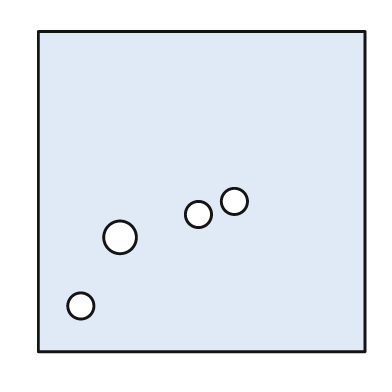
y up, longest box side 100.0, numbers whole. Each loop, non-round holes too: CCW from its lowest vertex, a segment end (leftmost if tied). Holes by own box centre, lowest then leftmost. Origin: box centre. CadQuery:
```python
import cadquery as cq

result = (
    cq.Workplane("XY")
    .moveTo(-50.0, -49.0)
    .lineTo(50.0, -49.0)
    .lineTo(50.0, 49.0)
    .lineTo(-50.0, 49.0)
    .close()
    .moveTo(-37.0, -35.0)
    .circle(4.0)
    .moveTo(-25.0, -14.0)
    .circle(5.0)
    .moveTo(-1.0, -7.0)
    .circle(4.0)
    .moveTo(10.0, -3.0)
    .circle(4.0)
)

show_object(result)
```